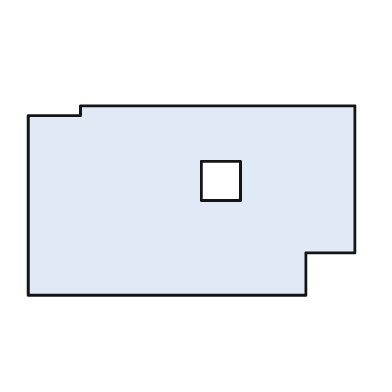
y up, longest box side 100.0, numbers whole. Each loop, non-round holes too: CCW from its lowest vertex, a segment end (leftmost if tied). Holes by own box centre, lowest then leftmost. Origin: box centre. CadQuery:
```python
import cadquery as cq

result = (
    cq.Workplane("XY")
    .moveTo(-50.0, -29.0)
    .lineTo(35.0, -29.0)
    .lineTo(35.0, -16.0)
    .lineTo(50.0, -16.0)
    .lineTo(50.0, 29.0)
    .lineTo(-34.0, 29.0)
    .lineTo(-34.0, 26.0)
    .lineTo(-50.0, 26.0)
    .close()
    .moveTo(3.0, 0.0)
    .lineTo(15.0, 0.0)
    .lineTo(15.0, 12.0)
    .lineTo(3.0, 12.0)
    .close()
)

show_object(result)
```